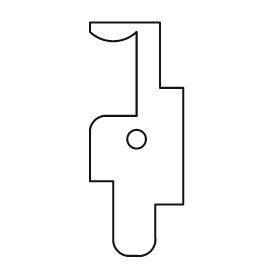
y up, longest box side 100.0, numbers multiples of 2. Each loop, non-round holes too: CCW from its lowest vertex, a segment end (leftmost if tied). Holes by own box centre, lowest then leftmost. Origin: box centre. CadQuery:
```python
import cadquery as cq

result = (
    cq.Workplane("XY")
    .moveTo(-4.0, -50.0)
    .lineTo(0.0, -50.0)
    .threePointArc((6.0, -48.0), (8.0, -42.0))
    .lineTo(8.0, -28.0)
    .lineTo(20.0, -28.0)
    .lineTo(20.0, 22.0)
    .lineTo(10.0, 22.0)
    .lineTo(10.0, 50.0)
    .lineTo(-20.0, 50.0)
    .lineTo(-20.0, 46.0)
    .threePointArc((-10.0, 42.0), (0.0, 46.0))
    .lineTo(0.0, 10.0)
    .lineTo(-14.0, 10.0)
    .threePointArc((-18.0, 8.0), (-20.0, 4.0))
    .lineTo(-20.0, -18.0)
    .lineTo(-10.0, -18.0)
    .lineTo(-10.0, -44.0)
    .threePointArc((-8.0, -48.0), (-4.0, -50.0))
    .close()
    .moveTo(0.0, 0.0)
    .circle(4.0)
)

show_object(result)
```